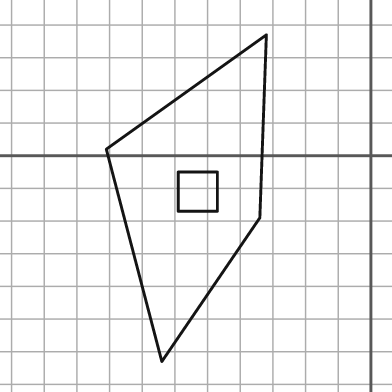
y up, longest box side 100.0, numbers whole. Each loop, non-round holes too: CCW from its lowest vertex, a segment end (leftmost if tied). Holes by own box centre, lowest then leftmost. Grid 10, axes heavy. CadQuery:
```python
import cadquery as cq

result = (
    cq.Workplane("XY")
    .moveTo(-64.0, -63.0)
    .lineTo(-34.0, -19.0)
    .lineTo(-32.0, 37.0)
    .lineTo(-81.0, 2.0)
    .close()
    .moveTo(-59.0, -17.0)
    .lineTo(-47.0, -17.0)
    .lineTo(-47.0, -5.0)
    .lineTo(-59.0, -5.0)
    .close()
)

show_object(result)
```